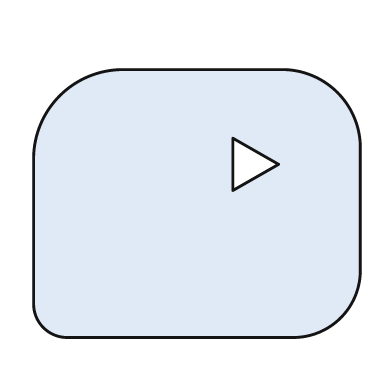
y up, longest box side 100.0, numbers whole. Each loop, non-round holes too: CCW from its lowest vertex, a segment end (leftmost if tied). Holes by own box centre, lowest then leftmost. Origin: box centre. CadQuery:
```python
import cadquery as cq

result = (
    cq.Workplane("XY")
    .moveTo(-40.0, -41.0)
    .lineTo(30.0, -41.0)
    .threePointArc((44.0, -35.0), (50.0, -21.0))
    .lineTo(50.0, 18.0)
    .threePointArc((43.0, 34.0), (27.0, 41.0))
    .lineTo(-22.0, 41.0)
    .threePointArc((-42.0, 33.0), (-50.0, 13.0))
    .lineTo(-50.0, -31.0)
    .threePointArc((-47.0, -38.0), (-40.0, -41.0))
    .close()
    .moveTo(11.0, 4.0)
    .lineTo(25.0, 12.0)
    .lineTo(11.0, 20.0)
    .close()
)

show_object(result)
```